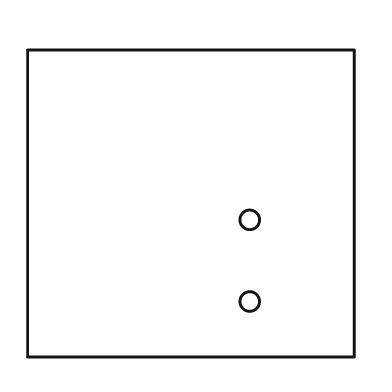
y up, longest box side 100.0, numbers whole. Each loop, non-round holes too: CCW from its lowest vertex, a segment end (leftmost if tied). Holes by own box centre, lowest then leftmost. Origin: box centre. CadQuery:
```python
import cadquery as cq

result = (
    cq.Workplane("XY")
    .moveTo(-50.0, -47.0)
    .lineTo(50.0, -47.0)
    .lineTo(50.0, 47.0)
    .lineTo(-50.0, 47.0)
    .close()
    .moveTo(18.0, -30.0)
    .circle(3.0)
    .moveTo(18.0, -5.0)
    .circle(3.0)
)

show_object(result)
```